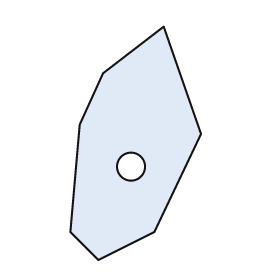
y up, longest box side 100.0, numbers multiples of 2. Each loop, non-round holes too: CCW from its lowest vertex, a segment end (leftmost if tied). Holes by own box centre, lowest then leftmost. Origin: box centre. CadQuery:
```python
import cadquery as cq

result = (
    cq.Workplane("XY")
    .moveTo(-16.0, -50.0)
    .lineTo(8.0, -38.0)
    .lineTo(28.0, 4.0)
    .lineTo(12.0, 50.0)
    .lineTo(-14.0, 30.0)
    .lineTo(-24.0, 8.0)
    .lineTo(-28.0, -38.0)
    .close()
    .moveTo(-2.0, -10.0)
    .circle(6.0)
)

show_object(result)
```